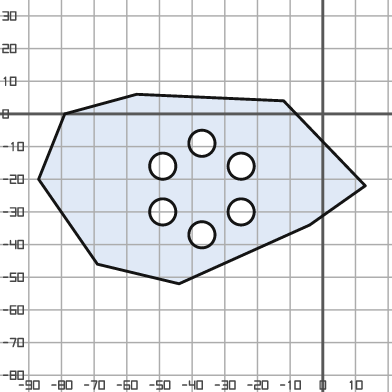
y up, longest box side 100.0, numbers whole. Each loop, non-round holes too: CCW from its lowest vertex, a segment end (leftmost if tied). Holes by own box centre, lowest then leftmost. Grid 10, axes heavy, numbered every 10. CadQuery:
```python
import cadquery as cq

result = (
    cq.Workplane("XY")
    .moveTo(-44.0, -52.0)
    .lineTo(-4.0, -34.0)
    .lineTo(13.0, -22.0)
    .lineTo(-12.0, 4.0)
    .lineTo(-57.0, 6.0)
    .lineTo(-79.0, 0.0)
    .lineTo(-87.0, -20.0)
    .lineTo(-69.0, -46.0)
    .close()
    .moveTo(-37.0, -37.0)
    .circle(4.0)
    .moveTo(-49.0, -30.0)
    .circle(4.0)
    .moveTo(-25.0, -30.0)
    .circle(4.0)
    .moveTo(-49.0, -16.0)
    .circle(4.0)
    .moveTo(-25.0, -16.0)
    .circle(4.0)
    .moveTo(-37.0, -9.0)
    .circle(4.0)
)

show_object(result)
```